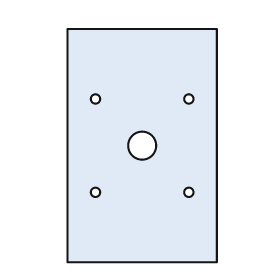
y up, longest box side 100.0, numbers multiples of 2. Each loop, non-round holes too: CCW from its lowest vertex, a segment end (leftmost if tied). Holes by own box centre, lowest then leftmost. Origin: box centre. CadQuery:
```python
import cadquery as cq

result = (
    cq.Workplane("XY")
    .moveTo(-32.0, -50.0)
    .lineTo(32.0, -50.0)
    .lineTo(32.0, 50.0)
    .lineTo(-32.0, 50.0)
    .close()
    .moveTo(-20.0, -20.0)
    .circle(2.0)
    .moveTo(20.0, -20.0)
    .circle(2.0)
    .moveTo(0.0, 0.0)
    .circle(6.0)
    .moveTo(-20.0, 20.0)
    .circle(2.0)
    .moveTo(20.0, 20.0)
    .circle(2.0)
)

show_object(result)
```